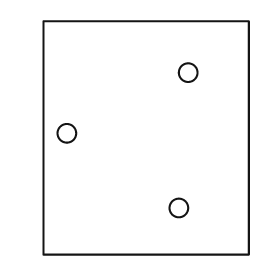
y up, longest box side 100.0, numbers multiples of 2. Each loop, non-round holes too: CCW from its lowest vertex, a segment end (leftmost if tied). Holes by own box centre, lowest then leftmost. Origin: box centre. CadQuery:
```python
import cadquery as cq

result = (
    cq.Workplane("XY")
    .moveTo(-44.0, -50.0)
    .lineTo(44.0, -50.0)
    .lineTo(44.0, 50.0)
    .lineTo(-44.0, 50.0)
    .close()
    .moveTo(14.0, -30.0)
    .circle(4.0)
    .moveTo(-34.0, 2.0)
    .circle(4.0)
    .moveTo(18.0, 28.0)
    .circle(4.0)
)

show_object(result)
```